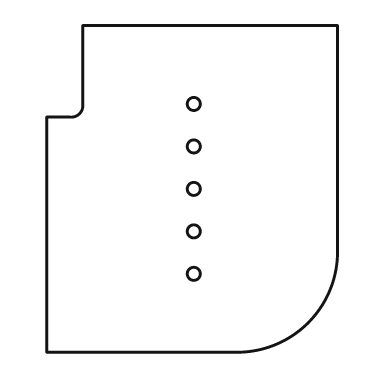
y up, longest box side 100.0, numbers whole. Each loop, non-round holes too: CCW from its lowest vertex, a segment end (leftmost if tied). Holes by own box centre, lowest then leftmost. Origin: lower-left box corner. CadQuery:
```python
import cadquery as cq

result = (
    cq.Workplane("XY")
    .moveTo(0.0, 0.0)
    .lineTo(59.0, 0.0)
    .threePointArc((80.0, 9.0), (89.0, 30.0))
    .lineTo(89.0, 100.0)
    .lineTo(11.0, 100.0)
    .lineTo(11.0, 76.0)
    .threePointArc((10.0, 73.0), (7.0, 72.0))
    .lineTo(0.0, 72.0)
    .close()
    .moveTo(45.0, 24.0)
    .circle(2.0)
    .moveTo(45.0, 37.0)
    .circle(2.0)
    .moveTo(45.0, 50.0)
    .circle(2.0)
    .moveTo(45.0, 63.0)
    .circle(2.0)
    .moveTo(45.0, 76.0)
    .circle(2.0)
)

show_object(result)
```